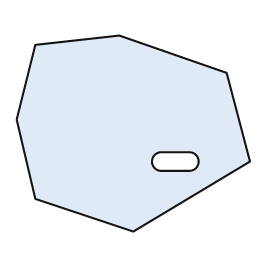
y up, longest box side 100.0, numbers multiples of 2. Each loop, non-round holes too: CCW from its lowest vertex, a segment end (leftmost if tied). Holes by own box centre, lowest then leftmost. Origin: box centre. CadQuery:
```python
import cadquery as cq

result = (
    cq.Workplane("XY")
    .moveTo(0.0, -42.0)
    .lineTo(50.0, -12.0)
    .lineTo(40.0, 26.0)
    .lineTo(-6.0, 42.0)
    .lineTo(-42.0, 38.0)
    .lineTo(-50.0, 6.0)
    .lineTo(-42.0, -28.0)
    .close()
    .moveTo(12.0, -16.0)
    .lineTo(24.0, -16.0)
    .threePointArc((28.0, -12.0), (24.0, -8.0))
    .lineTo(12.0, -8.0)
    .threePointArc((8.0, -12.0), (12.0, -16.0))
    .close()
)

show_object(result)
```